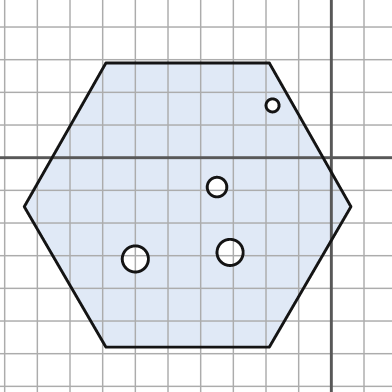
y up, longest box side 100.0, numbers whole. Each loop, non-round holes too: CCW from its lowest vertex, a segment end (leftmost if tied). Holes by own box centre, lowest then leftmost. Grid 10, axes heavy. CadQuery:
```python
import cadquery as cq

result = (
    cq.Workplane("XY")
    .moveTo(-69.0, -58.0)
    .lineTo(-19.0, -58.0)
    .lineTo(6.0, -15.0)
    .lineTo(-19.0, 29.0)
    .lineTo(-69.0, 29.0)
    .lineTo(-94.0, -15.0)
    .close()
    .moveTo(-60.0, -31.0)
    .circle(4.0)
    .moveTo(-31.0, -29.0)
    .circle(4.0)
    .moveTo(-35.0, -9.0)
    .circle(3.0)
    .moveTo(-18.0, 16.0)
    .circle(2.0)
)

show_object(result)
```